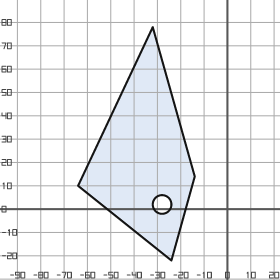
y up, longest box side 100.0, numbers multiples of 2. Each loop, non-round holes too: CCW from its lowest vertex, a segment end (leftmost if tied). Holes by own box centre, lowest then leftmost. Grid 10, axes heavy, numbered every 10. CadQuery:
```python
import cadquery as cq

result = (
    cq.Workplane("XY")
    .moveTo(-24.0, -22.0)
    .lineTo(-14.0, 14.0)
    .lineTo(-32.0, 78.0)
    .lineTo(-64.0, 10.0)
    .close()
    .moveTo(-28.0, 2.0)
    .circle(4.0)
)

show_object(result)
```